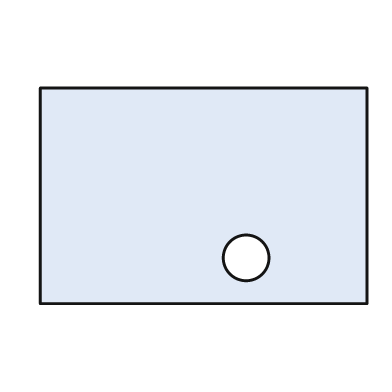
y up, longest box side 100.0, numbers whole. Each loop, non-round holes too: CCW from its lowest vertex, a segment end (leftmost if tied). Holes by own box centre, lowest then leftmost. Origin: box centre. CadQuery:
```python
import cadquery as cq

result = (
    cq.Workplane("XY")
    .moveTo(-50.0, -33.0)
    .lineTo(50.0, -33.0)
    .lineTo(50.0, 33.0)
    .lineTo(-50.0, 33.0)
    .close()
    .moveTo(13.0, -19.0)
    .circle(7.0)
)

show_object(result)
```